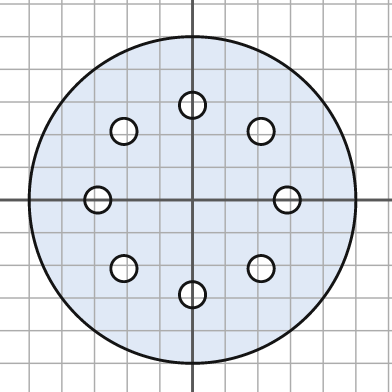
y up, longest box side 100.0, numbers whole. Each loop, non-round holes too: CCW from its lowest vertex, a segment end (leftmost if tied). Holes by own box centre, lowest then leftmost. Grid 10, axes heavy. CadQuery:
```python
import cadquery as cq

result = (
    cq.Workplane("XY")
    .moveTo(0.0, 0.0)
    .circle(50.0)
    .moveTo(0.0, -29.0)
    .circle(4.0)
    .moveTo(-21.0, -21.0)
    .circle(4.0)
    .moveTo(21.0, -21.0)
    .circle(4.0)
    .moveTo(-29.0, 0.0)
    .circle(4.0)
    .moveTo(29.0, 0.0)
    .circle(4.0)
    .moveTo(-21.0, 21.0)
    .circle(4.0)
    .moveTo(21.0, 21.0)
    .circle(4.0)
    .moveTo(0.0, 29.0)
    .circle(4.0)
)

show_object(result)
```